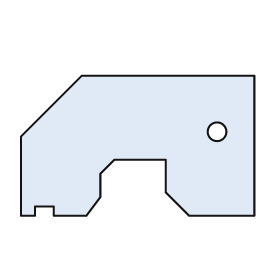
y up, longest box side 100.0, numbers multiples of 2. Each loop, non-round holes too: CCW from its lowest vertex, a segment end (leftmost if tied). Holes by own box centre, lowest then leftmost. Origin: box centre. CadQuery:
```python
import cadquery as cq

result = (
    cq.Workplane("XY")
    .moveTo(-50.0, -30.0)
    .lineTo(-44.0, -30.0)
    .lineTo(-44.0, -26.0)
    .lineTo(-36.0, -26.0)
    .lineTo(-36.0, -30.0)
    .lineTo(-22.0, -30.0)
    .lineTo(-16.0, -22.0)
    .lineTo(-16.0, -12.0)
    .lineTo(-10.0, -6.0)
    .lineTo(12.0, -6.0)
    .lineTo(12.0, -20.0)
    .lineTo(22.0, -30.0)
    .lineTo(50.0, -30.0)
    .lineTo(50.0, 30.0)
    .lineTo(-24.0, 30.0)
    .lineTo(-50.0, 4.0)
    .close()
    .moveTo(34.0, 6.0)
    .circle(4.0)
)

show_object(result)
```